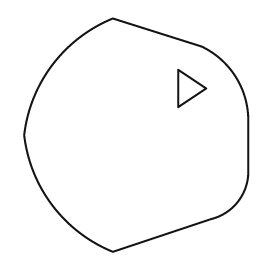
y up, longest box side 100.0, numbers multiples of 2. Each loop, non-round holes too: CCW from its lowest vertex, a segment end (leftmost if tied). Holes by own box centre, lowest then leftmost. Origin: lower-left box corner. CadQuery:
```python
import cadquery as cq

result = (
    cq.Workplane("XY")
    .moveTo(38.0, 0.0)
    .lineTo(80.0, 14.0)
    .threePointArc((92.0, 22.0), (96.0, 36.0))
    .lineTo(96.0, 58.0)
    .threePointArc((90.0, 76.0), (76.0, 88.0))
    .lineTo(38.0, 100.0)
    .threePointArc((12.0, 80.0), (0.0, 50.0))
    .threePointArc((12.0, 20.0), (38.0, 0.0))
    .close()
    .moveTo(66.0, 62.0)
    .lineTo(78.0, 70.0)
    .lineTo(66.0, 78.0)
    .close()
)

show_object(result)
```